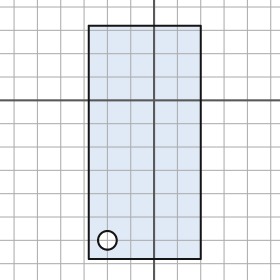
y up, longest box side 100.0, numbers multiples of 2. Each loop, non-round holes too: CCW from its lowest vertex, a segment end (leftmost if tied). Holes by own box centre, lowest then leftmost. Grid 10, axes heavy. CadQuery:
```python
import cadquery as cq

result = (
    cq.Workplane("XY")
    .moveTo(-28.0, -68.0)
    .lineTo(20.0, -68.0)
    .lineTo(20.0, 32.0)
    .lineTo(-28.0, 32.0)
    .close()
    .moveTo(-20.0, -60.0)
    .circle(4.0)
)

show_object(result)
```